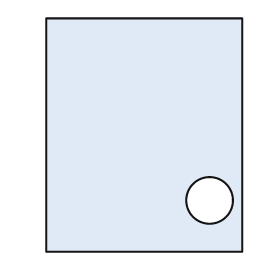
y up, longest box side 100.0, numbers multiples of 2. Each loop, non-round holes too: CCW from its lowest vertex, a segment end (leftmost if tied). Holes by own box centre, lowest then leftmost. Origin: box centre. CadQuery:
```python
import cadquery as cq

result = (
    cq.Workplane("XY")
    .moveTo(-42.0, -50.0)
    .lineTo(42.0, -50.0)
    .lineTo(42.0, 50.0)
    .lineTo(-42.0, 50.0)
    .close()
    .moveTo(28.0, -28.0)
    .circle(10.0)
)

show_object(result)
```